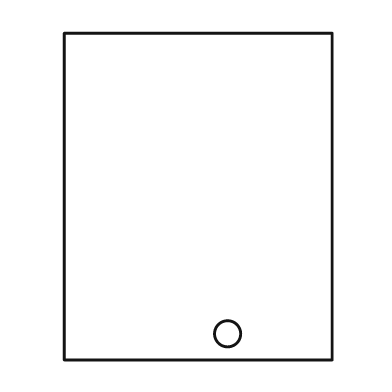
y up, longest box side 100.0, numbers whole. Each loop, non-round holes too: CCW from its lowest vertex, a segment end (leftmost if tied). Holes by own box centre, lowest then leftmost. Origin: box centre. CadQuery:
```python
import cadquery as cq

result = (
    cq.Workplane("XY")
    .moveTo(-41.0, -50.0)
    .lineTo(41.0, -50.0)
    .lineTo(41.0, 50.0)
    .lineTo(-41.0, 50.0)
    .close()
    .moveTo(9.0, -42.0)
    .circle(4.0)
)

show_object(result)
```